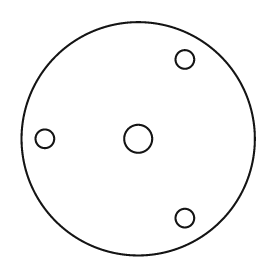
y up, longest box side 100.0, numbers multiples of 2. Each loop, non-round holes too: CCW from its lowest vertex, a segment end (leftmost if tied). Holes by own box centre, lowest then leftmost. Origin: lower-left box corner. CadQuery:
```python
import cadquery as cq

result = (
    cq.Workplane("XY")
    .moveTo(50.0, 50.0)
    .circle(50.0)
    .moveTo(70.0, 16.0)
    .circle(4.0)
    .moveTo(10.0, 50.0)
    .circle(4.0)
    .moveTo(50.0, 50.0)
    .circle(6.0)
    .moveTo(70.0, 84.0)
    .circle(4.0)
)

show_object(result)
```